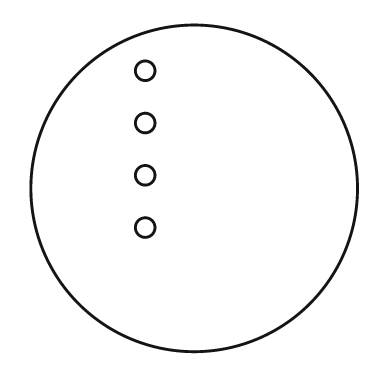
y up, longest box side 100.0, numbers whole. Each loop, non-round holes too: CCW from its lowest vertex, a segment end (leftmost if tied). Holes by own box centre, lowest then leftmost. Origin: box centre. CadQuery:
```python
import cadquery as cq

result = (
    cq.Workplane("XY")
    .moveTo(0.0, 0.0)
    .circle(50.0)
    .moveTo(-15.0, -12.0)
    .circle(3.0)
    .moveTo(-15.0, 4.0)
    .circle(3.0)
    .moveTo(-15.0, 20.0)
    .circle(3.0)
    .moveTo(-15.0, 36.0)
    .circle(3.0)
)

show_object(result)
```